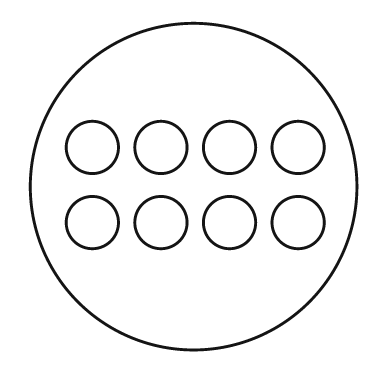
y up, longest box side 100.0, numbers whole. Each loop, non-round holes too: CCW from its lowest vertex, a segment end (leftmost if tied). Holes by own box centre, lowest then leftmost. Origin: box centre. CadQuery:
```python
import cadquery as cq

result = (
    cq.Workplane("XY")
    .moveTo(0.0, 0.0)
    .circle(50.0)
    .moveTo(-31.0, -11.0)
    .circle(8.0)
    .moveTo(-10.0, -11.0)
    .circle(8.0)
    .moveTo(11.0, -11.0)
    .circle(8.0)
    .moveTo(32.0, -11.0)
    .circle(8.0)
    .moveTo(-31.0, 12.0)
    .circle(8.0)
    .moveTo(-10.0, 12.0)
    .circle(8.0)
    .moveTo(11.0, 12.0)
    .circle(8.0)
    .moveTo(32.0, 12.0)
    .circle(8.0)
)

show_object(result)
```